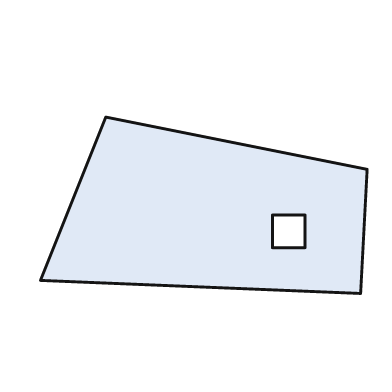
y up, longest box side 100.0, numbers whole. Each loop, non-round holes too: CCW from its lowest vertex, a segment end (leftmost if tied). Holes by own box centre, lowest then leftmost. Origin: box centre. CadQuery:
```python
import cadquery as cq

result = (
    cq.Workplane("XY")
    .moveTo(48.0, -27.0)
    .lineTo(50.0, 11.0)
    .lineTo(-30.0, 27.0)
    .lineTo(-50.0, -23.0)
    .close()
    .moveTo(21.0, -13.0)
    .lineTo(31.0, -13.0)
    .lineTo(31.0, -3.0)
    .lineTo(21.0, -3.0)
    .close()
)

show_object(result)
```